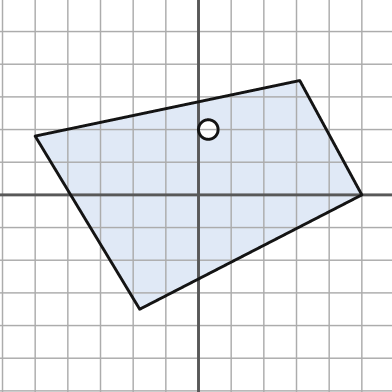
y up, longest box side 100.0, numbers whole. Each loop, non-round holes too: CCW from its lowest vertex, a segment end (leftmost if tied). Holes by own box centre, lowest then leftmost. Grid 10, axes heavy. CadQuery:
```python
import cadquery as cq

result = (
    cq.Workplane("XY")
    .moveTo(-18.0, -35.0)
    .lineTo(50.0, 0.0)
    .lineTo(31.0, 35.0)
    .lineTo(-50.0, 18.0)
    .close()
    .moveTo(3.0, 20.0)
    .circle(3.0)
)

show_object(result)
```